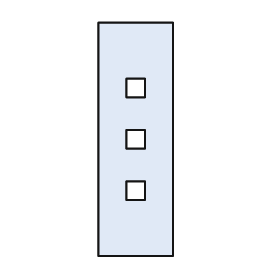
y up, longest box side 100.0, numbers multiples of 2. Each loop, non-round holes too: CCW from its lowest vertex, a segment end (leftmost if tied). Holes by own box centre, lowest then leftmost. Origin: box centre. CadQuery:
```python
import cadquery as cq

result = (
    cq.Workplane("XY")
    .moveTo(-16.0, -50.0)
    .lineTo(16.0, -50.0)
    .lineTo(16.0, 50.0)
    .lineTo(-16.0, 50.0)
    .close()
    .moveTo(-4.0, -26.0)
    .lineTo(4.0, -26.0)
    .lineTo(4.0, -18.0)
    .lineTo(-4.0, -18.0)
    .close()
    .moveTo(-4.0, -4.0)
    .lineTo(4.0, -4.0)
    .lineTo(4.0, 4.0)
    .lineTo(-4.0, 4.0)
    .close()
    .moveTo(-4.0, 18.0)
    .lineTo(4.0, 18.0)
    .lineTo(4.0, 26.0)
    .lineTo(-4.0, 26.0)
    .close()
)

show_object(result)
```